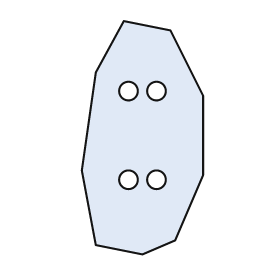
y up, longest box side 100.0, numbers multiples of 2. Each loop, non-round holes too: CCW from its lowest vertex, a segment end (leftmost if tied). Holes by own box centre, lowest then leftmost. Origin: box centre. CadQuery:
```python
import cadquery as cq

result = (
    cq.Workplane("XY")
    .moveTo(0.0, -50.0)
    .lineTo(14.0, -44.0)
    .lineTo(26.0, -16.0)
    .lineTo(26.0, 18.0)
    .lineTo(12.0, 46.0)
    .lineTo(-8.0, 50.0)
    .lineTo(-20.0, 28.0)
    .lineTo(-26.0, -14.0)
    .lineTo(-20.0, -46.0)
    .close()
    .moveTo(-6.0, -18.0)
    .circle(4.0)
    .moveTo(6.0, -18.0)
    .circle(4.0)
    .moveTo(-6.0, 20.0)
    .circle(4.0)
    .moveTo(6.0, 20.0)
    .circle(4.0)
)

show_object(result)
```